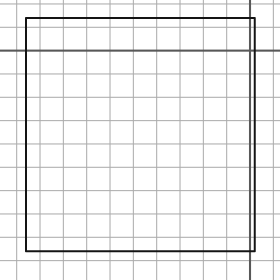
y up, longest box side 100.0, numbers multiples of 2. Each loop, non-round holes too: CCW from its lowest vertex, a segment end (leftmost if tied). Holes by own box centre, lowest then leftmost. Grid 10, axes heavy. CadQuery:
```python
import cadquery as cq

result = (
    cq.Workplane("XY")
    .moveTo(-96.0, -86.0)
    .lineTo(2.0, -86.0)
    .lineTo(2.0, 14.0)
    .lineTo(-96.0, 14.0)
    .close()
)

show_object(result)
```